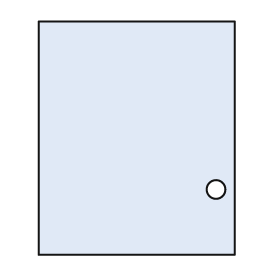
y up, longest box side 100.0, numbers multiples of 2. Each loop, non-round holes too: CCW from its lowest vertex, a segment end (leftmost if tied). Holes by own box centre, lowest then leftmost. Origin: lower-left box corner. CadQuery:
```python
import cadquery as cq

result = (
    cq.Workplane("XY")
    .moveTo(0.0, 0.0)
    .lineTo(84.0, 0.0)
    .lineTo(84.0, 100.0)
    .lineTo(0.0, 100.0)
    .close()
    .moveTo(76.0, 28.0)
    .circle(4.0)
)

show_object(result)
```